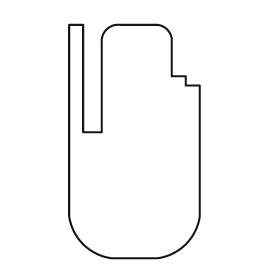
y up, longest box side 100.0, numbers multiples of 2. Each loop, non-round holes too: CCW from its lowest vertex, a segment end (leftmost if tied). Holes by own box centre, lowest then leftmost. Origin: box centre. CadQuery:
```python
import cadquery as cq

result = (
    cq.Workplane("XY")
    .moveTo(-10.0, -50.0)
    .lineTo(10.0, -50.0)
    .threePointArc((22.0, -44.0), (28.0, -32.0))
    .lineTo(28.0, 24.0)
    .lineTo(22.0, 24.0)
    .lineTo(22.0, 28.0)
    .lineTo(16.0, 28.0)
    .lineTo(16.0, 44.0)
    .threePointArc((14.0, 48.0), (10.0, 50.0))
    .lineTo(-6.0, 50.0)
    .threePointArc((-12.0, 48.0), (-14.0, 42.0))
    .lineTo(-14.0, 4.0)
    .lineTo(-22.0, 4.0)
    .lineTo(-22.0, 50.0)
    .lineTo(-28.0, 50.0)
    .lineTo(-28.0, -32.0)
    .threePointArc((-22.0, -44.0), (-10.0, -50.0))
    .close()
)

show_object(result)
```